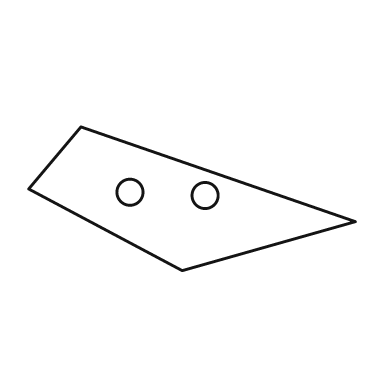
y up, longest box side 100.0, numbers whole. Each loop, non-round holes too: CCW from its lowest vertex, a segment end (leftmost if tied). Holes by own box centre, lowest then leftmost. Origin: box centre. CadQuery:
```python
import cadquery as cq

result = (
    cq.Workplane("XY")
    .moveTo(-3.0, -22.0)
    .lineTo(50.0, -7.0)
    .lineTo(-34.0, 22.0)
    .lineTo(-50.0, 3.0)
    .close()
    .moveTo(4.0, 1.0)
    .circle(4.0)
    .moveTo(-19.0, 2.0)
    .circle(4.0)
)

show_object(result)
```